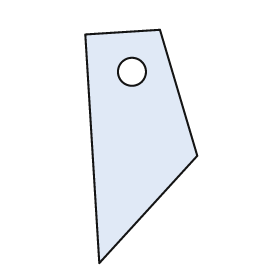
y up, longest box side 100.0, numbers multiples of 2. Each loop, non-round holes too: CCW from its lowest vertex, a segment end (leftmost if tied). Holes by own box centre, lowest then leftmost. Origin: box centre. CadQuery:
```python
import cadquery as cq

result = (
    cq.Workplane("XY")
    .moveTo(-18.0, -50.0)
    .lineTo(24.0, -4.0)
    .lineTo(8.0, 50.0)
    .lineTo(-24.0, 48.0)
    .close()
    .moveTo(-4.0, 32.0)
    .circle(6.0)
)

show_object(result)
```